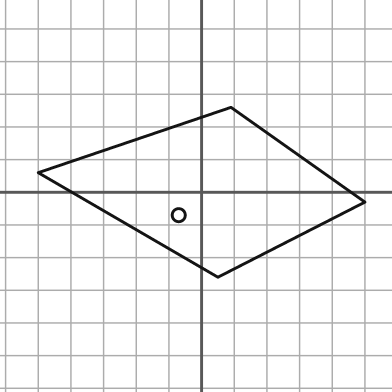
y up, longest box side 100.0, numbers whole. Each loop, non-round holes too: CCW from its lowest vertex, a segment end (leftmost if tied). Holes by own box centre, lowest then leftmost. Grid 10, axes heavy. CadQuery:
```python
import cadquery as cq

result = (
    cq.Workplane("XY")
    .moveTo(5.0, -26.0)
    .lineTo(50.0, -3.0)
    .lineTo(9.0, 26.0)
    .lineTo(-50.0, 6.0)
    .close()
    .moveTo(-7.0, -7.0)
    .circle(2.0)
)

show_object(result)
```